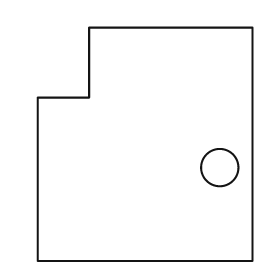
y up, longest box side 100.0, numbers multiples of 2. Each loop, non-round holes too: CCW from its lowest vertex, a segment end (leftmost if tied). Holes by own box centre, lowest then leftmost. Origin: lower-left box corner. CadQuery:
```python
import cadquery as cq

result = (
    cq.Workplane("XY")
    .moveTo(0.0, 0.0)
    .lineTo(92.0, 0.0)
    .lineTo(92.0, 100.0)
    .lineTo(22.0, 100.0)
    .lineTo(22.0, 70.0)
    .lineTo(0.0, 70.0)
    .close()
    .moveTo(78.0, 40.0)
    .circle(8.0)
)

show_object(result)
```